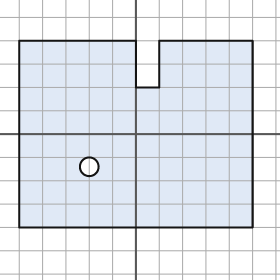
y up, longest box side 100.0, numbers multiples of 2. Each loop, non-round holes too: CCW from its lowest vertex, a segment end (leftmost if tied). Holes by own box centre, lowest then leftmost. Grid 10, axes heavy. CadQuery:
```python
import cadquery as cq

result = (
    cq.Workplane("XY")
    .moveTo(-50.0, -40.0)
    .lineTo(50.0, -40.0)
    .lineTo(50.0, 40.0)
    .lineTo(10.0, 40.0)
    .lineTo(10.0, 20.0)
    .lineTo(0.0, 20.0)
    .lineTo(0.0, 40.0)
    .lineTo(-50.0, 40.0)
    .close()
    .moveTo(-20.0, -14.0)
    .circle(4.0)
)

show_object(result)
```